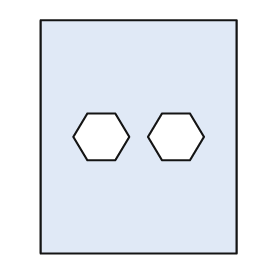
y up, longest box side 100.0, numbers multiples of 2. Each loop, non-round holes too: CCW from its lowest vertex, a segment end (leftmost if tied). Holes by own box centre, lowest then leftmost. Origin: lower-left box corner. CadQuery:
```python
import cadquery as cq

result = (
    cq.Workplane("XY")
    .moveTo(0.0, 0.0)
    .lineTo(84.0, 0.0)
    .lineTo(84.0, 100.0)
    .lineTo(0.0, 100.0)
    .close()
    .moveTo(20.0, 40.0)
    .lineTo(32.0, 40.0)
    .lineTo(38.0, 50.0)
    .lineTo(32.0, 60.0)
    .lineTo(20.0, 60.0)
    .lineTo(14.0, 50.0)
    .close()
    .moveTo(52.0, 40.0)
    .lineTo(64.0, 40.0)
    .lineTo(70.0, 50.0)
    .lineTo(64.0, 60.0)
    .lineTo(52.0, 60.0)
    .lineTo(46.0, 50.0)
    .close()
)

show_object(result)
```